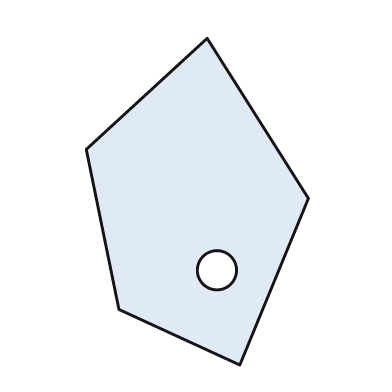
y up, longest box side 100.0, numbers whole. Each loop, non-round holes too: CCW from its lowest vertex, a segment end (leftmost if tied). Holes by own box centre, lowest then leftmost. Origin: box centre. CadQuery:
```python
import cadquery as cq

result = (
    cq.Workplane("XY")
    .moveTo(13.0, -50.0)
    .lineTo(34.0, 1.0)
    .lineTo(3.0, 50.0)
    .lineTo(-34.0, 16.0)
    .lineTo(-24.0, -33.0)
    .close()
    .moveTo(6.0, -21.0)
    .circle(6.0)
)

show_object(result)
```